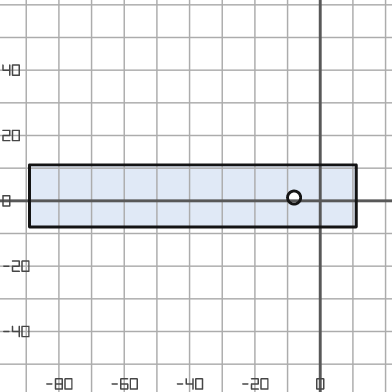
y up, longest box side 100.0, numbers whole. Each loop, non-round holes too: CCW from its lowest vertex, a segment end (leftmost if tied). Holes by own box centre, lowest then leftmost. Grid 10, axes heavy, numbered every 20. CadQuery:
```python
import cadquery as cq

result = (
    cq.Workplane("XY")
    .moveTo(-89.0, -8.0)
    .lineTo(11.0, -8.0)
    .lineTo(11.0, 11.0)
    .lineTo(-89.0, 11.0)
    .close()
    .moveTo(-8.0, 1.0)
    .circle(2.0)
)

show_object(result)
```